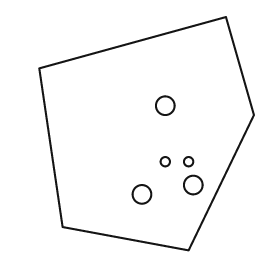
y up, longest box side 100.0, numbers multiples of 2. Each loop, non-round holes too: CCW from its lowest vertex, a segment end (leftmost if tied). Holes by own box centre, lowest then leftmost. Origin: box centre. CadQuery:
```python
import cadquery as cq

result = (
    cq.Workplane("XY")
    .moveTo(18.0, -50.0)
    .lineTo(46.0, 8.0)
    .lineTo(34.0, 50.0)
    .lineTo(-46.0, 28.0)
    .lineTo(-36.0, -40.0)
    .close()
    .moveTo(-2.0, -26.0)
    .circle(4.0)
    .moveTo(20.0, -22.0)
    .circle(4.0)
    .moveTo(8.0, -12.0)
    .circle(2.0)
    .moveTo(18.0, -12.0)
    .circle(2.0)
    .moveTo(8.0, 12.0)
    .circle(4.0)
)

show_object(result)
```